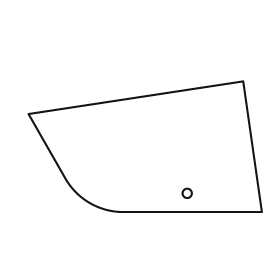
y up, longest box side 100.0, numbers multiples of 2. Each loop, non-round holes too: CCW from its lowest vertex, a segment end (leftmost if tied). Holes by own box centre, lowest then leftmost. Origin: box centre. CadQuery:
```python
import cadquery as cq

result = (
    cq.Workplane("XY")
    .moveTo(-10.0, -28.0)
    .lineTo(50.0, -28.0)
    .lineTo(42.0, 28.0)
    .lineTo(-50.0, 14.0)
    .lineTo(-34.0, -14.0)
    .threePointArc((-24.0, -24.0), (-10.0, -28.0))
    .close()
    .moveTo(18.0, -20.0)
    .circle(2.0)
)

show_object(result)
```